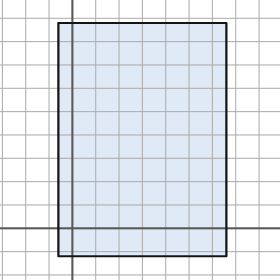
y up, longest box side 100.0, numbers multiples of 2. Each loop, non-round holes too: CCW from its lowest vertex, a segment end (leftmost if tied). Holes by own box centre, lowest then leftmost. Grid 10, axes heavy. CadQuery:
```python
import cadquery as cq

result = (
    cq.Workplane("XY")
    .moveTo(-6.0, -12.0)
    .lineTo(66.0, -12.0)
    .lineTo(66.0, 88.0)
    .lineTo(-6.0, 88.0)
    .close()
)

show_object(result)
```